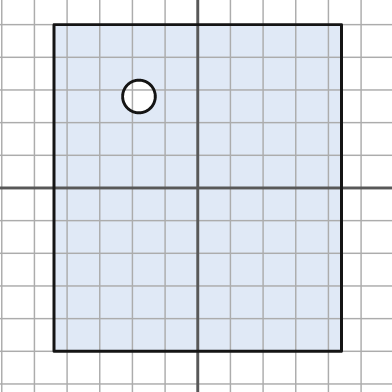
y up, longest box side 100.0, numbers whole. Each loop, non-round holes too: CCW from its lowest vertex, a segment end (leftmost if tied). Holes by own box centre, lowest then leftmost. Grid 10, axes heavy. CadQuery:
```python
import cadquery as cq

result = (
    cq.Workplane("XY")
    .moveTo(-44.0, -50.0)
    .lineTo(44.0, -50.0)
    .lineTo(44.0, 50.0)
    .lineTo(-44.0, 50.0)
    .close()
    .moveTo(-18.0, 28.0)
    .circle(5.0)
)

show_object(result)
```